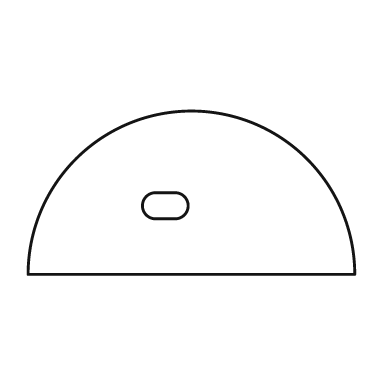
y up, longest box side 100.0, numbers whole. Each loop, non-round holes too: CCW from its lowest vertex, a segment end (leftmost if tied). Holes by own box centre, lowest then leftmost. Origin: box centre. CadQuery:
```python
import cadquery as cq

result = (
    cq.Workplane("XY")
    .moveTo(-50.0, -25.0)
    .lineTo(50.0, -25.0)
    .threePointArc((0.0, 25.0), (-50.0, -25.0))
    .close()
    .moveTo(-11.0, -8.0)
    .lineTo(-5.0, -8.0)
    .threePointArc((-1.0, -4.0), (-5.0, 0.0))
    .lineTo(-11.0, 0.0)
    .threePointArc((-15.0, -4.0), (-11.0, -8.0))
    .close()
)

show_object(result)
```